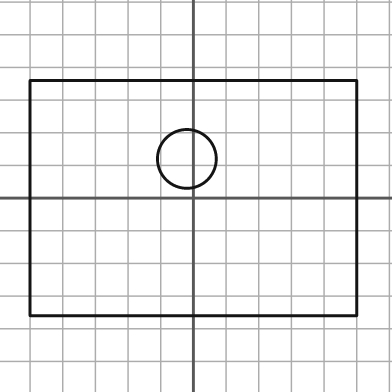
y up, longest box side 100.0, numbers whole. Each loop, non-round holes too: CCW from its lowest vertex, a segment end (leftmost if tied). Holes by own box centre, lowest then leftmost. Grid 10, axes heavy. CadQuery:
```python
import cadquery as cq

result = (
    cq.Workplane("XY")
    .moveTo(-50.0, -36.0)
    .lineTo(50.0, -36.0)
    .lineTo(50.0, 36.0)
    .lineTo(-50.0, 36.0)
    .close()
    .moveTo(-2.0, 12.0)
    .circle(9.0)
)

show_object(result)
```